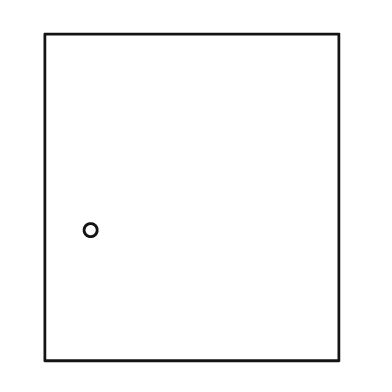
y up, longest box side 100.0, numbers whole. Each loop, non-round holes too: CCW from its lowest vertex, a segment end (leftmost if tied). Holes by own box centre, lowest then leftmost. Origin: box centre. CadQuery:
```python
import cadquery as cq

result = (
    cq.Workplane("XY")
    .moveTo(-45.0, -50.0)
    .lineTo(45.0, -50.0)
    .lineTo(45.0, 50.0)
    .lineTo(-45.0, 50.0)
    .close()
    .moveTo(-31.0, -10.0)
    .circle(2.0)
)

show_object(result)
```